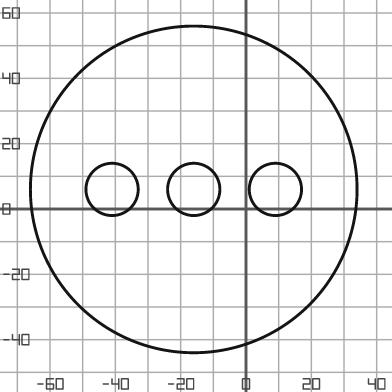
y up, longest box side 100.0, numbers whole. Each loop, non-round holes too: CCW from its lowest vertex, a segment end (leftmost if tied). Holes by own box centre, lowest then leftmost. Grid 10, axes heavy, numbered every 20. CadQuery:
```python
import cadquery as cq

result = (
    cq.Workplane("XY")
    .moveTo(-16.0, 6.0)
    .circle(50.0)
    .moveTo(-41.0, 6.0)
    .circle(8.0)
    .moveTo(-16.0, 6.0)
    .circle(8.0)
    .moveTo(9.0, 6.0)
    .circle(8.0)
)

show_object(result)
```